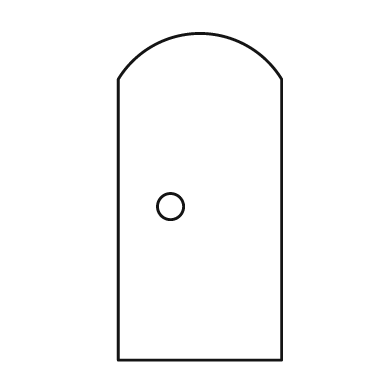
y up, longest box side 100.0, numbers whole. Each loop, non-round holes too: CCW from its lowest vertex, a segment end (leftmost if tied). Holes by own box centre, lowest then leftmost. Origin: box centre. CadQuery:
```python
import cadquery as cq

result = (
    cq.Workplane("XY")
    .moveTo(-25.0, -50.0)
    .lineTo(25.0, -50.0)
    .lineTo(25.0, 36.0)
    .threePointArc((0.0, 50.0), (-25.0, 36.0))
    .close()
    .moveTo(-9.0, -3.0)
    .circle(4.0)
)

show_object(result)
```